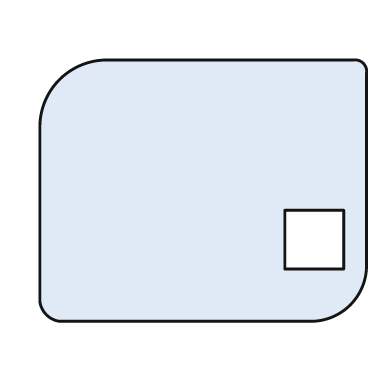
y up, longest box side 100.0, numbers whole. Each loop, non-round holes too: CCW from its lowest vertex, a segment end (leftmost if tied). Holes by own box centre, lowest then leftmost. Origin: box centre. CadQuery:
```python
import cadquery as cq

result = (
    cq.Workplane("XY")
    .moveTo(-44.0, -40.0)
    .lineTo(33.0, -40.0)
    .threePointArc((45.0, -35.0), (50.0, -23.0))
    .lineTo(50.0, 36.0)
    .threePointArc((49.0, 39.0), (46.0, 40.0))
    .lineTo(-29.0, 40.0)
    .threePointArc((-44.0, 34.0), (-50.0, 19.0))
    .lineTo(-50.0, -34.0)
    .threePointArc((-48.0, -38.0), (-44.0, -40.0))
    .close()
    .moveTo(25.0, -24.0)
    .lineTo(43.0, -24.0)
    .lineTo(43.0, -6.0)
    .lineTo(25.0, -6.0)
    .close()
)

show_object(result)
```